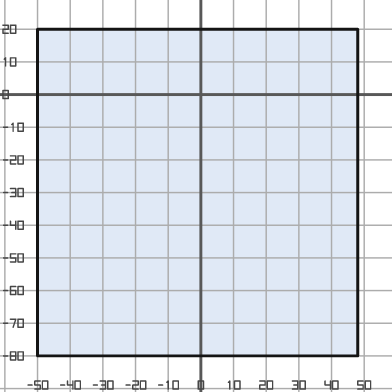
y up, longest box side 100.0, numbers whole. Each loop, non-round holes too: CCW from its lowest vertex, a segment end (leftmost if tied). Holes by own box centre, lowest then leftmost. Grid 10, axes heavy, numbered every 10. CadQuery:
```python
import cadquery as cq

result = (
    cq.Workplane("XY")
    .moveTo(-50.0, -80.0)
    .lineTo(48.0, -80.0)
    .lineTo(48.0, 20.0)
    .lineTo(-50.0, 20.0)
    .close()
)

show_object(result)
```